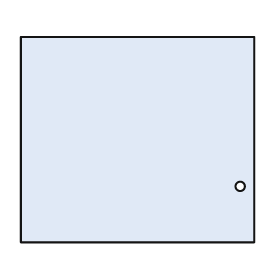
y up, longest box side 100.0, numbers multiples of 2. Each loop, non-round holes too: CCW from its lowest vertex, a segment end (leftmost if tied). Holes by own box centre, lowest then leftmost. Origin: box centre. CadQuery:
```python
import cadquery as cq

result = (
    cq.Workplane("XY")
    .moveTo(-50.0, -44.0)
    .lineTo(50.0, -44.0)
    .lineTo(50.0, 44.0)
    .lineTo(-50.0, 44.0)
    .close()
    .moveTo(44.0, -20.0)
    .circle(2.0)
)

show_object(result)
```